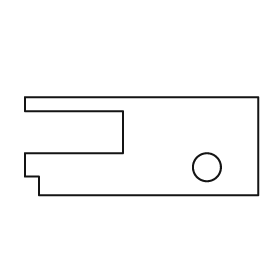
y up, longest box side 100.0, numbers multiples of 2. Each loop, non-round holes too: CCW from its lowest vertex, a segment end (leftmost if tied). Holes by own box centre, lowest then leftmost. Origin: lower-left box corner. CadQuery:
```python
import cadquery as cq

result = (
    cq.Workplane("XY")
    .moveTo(6.0, 0.0)
    .lineTo(100.0, 0.0)
    .lineTo(100.0, 42.0)
    .lineTo(0.0, 42.0)
    .lineTo(0.0, 36.0)
    .lineTo(42.0, 36.0)
    .lineTo(42.0, 18.0)
    .lineTo(0.0, 18.0)
    .lineTo(0.0, 8.0)
    .lineTo(6.0, 8.0)
    .close()
    .moveTo(78.0, 12.0)
    .circle(6.0)
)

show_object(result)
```